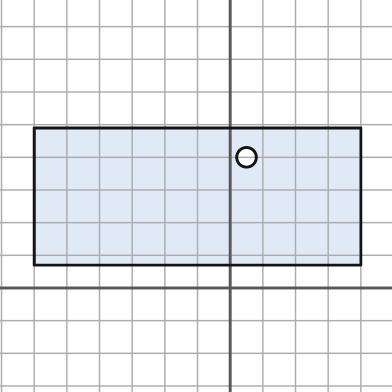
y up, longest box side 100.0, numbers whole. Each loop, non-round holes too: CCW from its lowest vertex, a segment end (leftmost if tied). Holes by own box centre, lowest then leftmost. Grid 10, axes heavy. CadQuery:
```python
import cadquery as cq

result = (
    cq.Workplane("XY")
    .moveTo(-60.0, 7.0)
    .lineTo(40.0, 7.0)
    .lineTo(40.0, 49.0)
    .lineTo(-60.0, 49.0)
    .close()
    .moveTo(5.0, 40.0)
    .circle(3.0)
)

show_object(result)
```